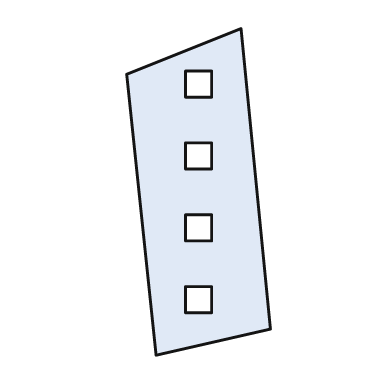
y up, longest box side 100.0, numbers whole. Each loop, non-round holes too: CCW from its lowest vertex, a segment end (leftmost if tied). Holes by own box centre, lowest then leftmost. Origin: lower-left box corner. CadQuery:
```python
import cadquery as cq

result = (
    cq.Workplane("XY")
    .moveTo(9.0, 0.0)
    .lineTo(44.0, 8.0)
    .lineTo(35.0, 100.0)
    .lineTo(0.0, 86.0)
    .close()
    .moveTo(18.0, 13.0)
    .lineTo(26.0, 13.0)
    .lineTo(26.0, 21.0)
    .lineTo(18.0, 21.0)
    .close()
    .moveTo(18.0, 35.0)
    .lineTo(26.0, 35.0)
    .lineTo(26.0, 43.0)
    .lineTo(18.0, 43.0)
    .close()
    .moveTo(18.0, 57.0)
    .lineTo(26.0, 57.0)
    .lineTo(26.0, 65.0)
    .lineTo(18.0, 65.0)
    .close()
    .moveTo(18.0, 79.0)
    .lineTo(26.0, 79.0)
    .lineTo(26.0, 87.0)
    .lineTo(18.0, 87.0)
    .close()
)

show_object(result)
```